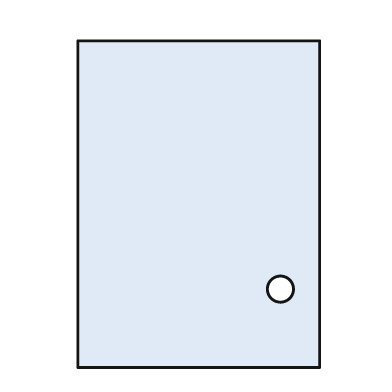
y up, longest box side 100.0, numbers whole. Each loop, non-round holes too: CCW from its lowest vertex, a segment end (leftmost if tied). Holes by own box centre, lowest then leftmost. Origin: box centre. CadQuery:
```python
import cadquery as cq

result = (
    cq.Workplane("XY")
    .moveTo(-37.0, -50.0)
    .lineTo(37.0, -50.0)
    .lineTo(37.0, 50.0)
    .lineTo(-37.0, 50.0)
    .close()
    .moveTo(25.0, -26.0)
    .circle(4.0)
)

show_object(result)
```